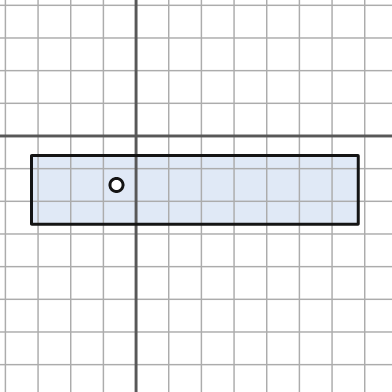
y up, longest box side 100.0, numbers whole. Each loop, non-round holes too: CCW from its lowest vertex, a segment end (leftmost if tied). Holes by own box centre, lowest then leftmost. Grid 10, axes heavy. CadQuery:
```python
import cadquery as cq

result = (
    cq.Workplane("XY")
    .moveTo(-32.0, -27.0)
    .lineTo(68.0, -27.0)
    .lineTo(68.0, -6.0)
    .lineTo(-32.0, -6.0)
    .close()
    .moveTo(-6.0, -15.0)
    .circle(2.0)
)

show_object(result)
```